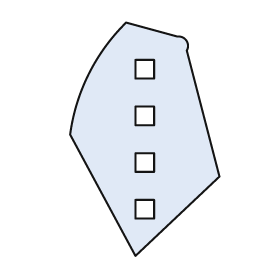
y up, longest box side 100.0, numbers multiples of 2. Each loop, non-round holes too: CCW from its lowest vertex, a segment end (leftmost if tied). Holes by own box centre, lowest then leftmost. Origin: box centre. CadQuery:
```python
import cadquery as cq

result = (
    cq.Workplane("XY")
    .moveTo(-4.0, -50.0)
    .lineTo(32.0, -16.0)
    .lineTo(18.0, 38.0)
    .threePointArc((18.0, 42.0), (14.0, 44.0))
    .lineTo(-8.0, 50.0)
    .threePointArc((-24.0, 28.0), (-32.0, 2.0))
    .close()
    .moveTo(-4.0, -34.0)
    .lineTo(4.0, -34.0)
    .lineTo(4.0, -26.0)
    .lineTo(-4.0, -26.0)
    .close()
    .moveTo(-4.0, -14.0)
    .lineTo(4.0, -14.0)
    .lineTo(4.0, -6.0)
    .lineTo(-4.0, -6.0)
    .close()
    .moveTo(-4.0, 6.0)
    .lineTo(4.0, 6.0)
    .lineTo(4.0, 14.0)
    .lineTo(-4.0, 14.0)
    .close()
    .moveTo(-4.0, 26.0)
    .lineTo(4.0, 26.0)
    .lineTo(4.0, 34.0)
    .lineTo(-4.0, 34.0)
    .close()
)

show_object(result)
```